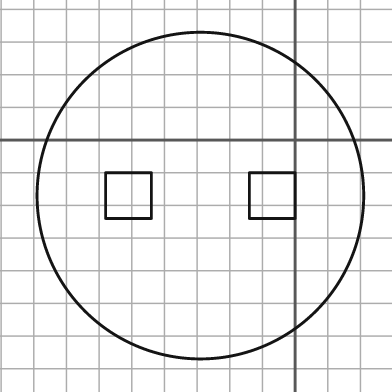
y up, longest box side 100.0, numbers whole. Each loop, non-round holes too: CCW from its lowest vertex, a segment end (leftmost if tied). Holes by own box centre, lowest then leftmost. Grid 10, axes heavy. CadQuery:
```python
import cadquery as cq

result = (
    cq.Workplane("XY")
    .moveTo(-29.0, -17.0)
    .circle(50.0)
    .moveTo(-58.0, -24.0)
    .lineTo(-44.0, -24.0)
    .lineTo(-44.0, -10.0)
    .lineTo(-58.0, -10.0)
    .close()
    .moveTo(-14.0, -24.0)
    .lineTo(0.0, -24.0)
    .lineTo(0.0, -10.0)
    .lineTo(-14.0, -10.0)
    .close()
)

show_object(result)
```